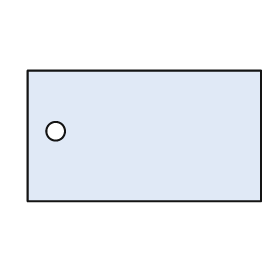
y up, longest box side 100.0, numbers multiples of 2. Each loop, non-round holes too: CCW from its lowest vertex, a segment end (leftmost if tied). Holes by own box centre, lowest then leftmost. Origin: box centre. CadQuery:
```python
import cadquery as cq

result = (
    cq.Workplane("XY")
    .moveTo(-50.0, -28.0)
    .lineTo(50.0, -28.0)
    .lineTo(50.0, 28.0)
    .lineTo(-50.0, 28.0)
    .close()
    .moveTo(-38.0, 2.0)
    .circle(4.0)
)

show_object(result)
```